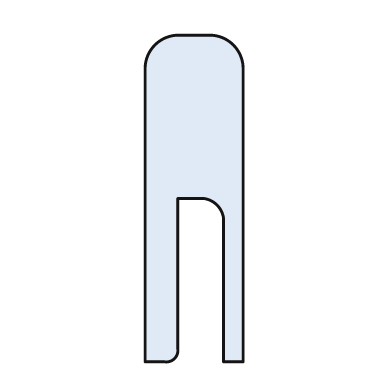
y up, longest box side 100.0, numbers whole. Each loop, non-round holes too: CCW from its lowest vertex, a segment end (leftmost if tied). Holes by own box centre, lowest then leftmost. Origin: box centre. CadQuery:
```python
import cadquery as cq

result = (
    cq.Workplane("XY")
    .moveTo(-15.0, -50.0)
    .lineTo(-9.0, -50.0)
    .threePointArc((-6.0, -49.0), (-5.0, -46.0))
    .lineTo(-5.0, 0.0)
    .lineTo(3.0, 0.0)
    .threePointArc((7.0, -2.0), (9.0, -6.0))
    .lineTo(9.0, -50.0)
    .lineTo(15.0, -50.0)
    .lineTo(15.0, 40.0)
    .threePointArc((12.0, 47.0), (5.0, 50.0))
    .lineTo(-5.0, 50.0)
    .threePointArc((-12.0, 47.0), (-15.0, 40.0))
    .close()
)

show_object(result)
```